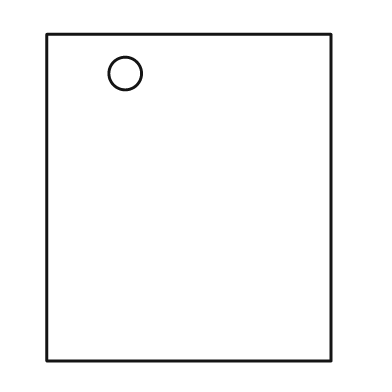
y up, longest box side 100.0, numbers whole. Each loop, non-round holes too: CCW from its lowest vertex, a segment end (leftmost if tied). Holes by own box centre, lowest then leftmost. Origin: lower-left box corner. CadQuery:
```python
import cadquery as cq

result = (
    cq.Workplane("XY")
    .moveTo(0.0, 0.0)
    .lineTo(87.0, 0.0)
    .lineTo(87.0, 100.0)
    .lineTo(0.0, 100.0)
    .close()
    .moveTo(24.0, 88.0)
    .circle(5.0)
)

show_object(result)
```